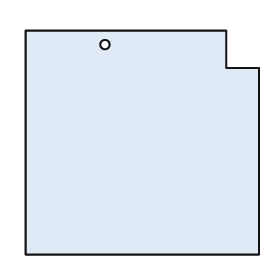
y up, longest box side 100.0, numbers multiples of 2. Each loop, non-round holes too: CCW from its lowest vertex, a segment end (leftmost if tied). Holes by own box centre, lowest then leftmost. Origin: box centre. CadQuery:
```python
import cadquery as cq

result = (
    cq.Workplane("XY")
    .moveTo(-50.0, -48.0)
    .lineTo(50.0, -48.0)
    .lineTo(50.0, 32.0)
    .lineTo(36.0, 32.0)
    .lineTo(36.0, 48.0)
    .lineTo(-50.0, 48.0)
    .close()
    .moveTo(-16.0, 42.0)
    .circle(2.0)
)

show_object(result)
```